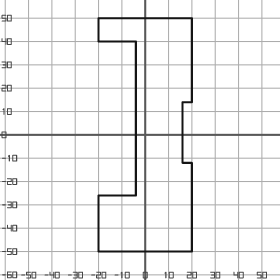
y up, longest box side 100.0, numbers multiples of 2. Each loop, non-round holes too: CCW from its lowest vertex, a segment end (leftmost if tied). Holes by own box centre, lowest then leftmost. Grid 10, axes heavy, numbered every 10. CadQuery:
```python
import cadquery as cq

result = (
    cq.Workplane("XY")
    .moveTo(-20.0, -50.0)
    .lineTo(20.0, -50.0)
    .lineTo(20.0, -12.0)
    .lineTo(16.0, -12.0)
    .lineTo(16.0, 14.0)
    .lineTo(20.0, 14.0)
    .lineTo(20.0, 50.0)
    .lineTo(-20.0, 50.0)
    .lineTo(-20.0, 40.0)
    .lineTo(-4.0, 40.0)
    .lineTo(-4.0, -26.0)
    .lineTo(-20.0, -26.0)
    .close()
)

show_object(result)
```